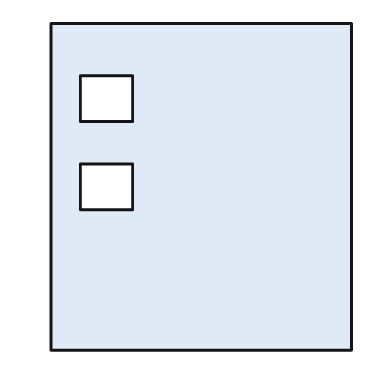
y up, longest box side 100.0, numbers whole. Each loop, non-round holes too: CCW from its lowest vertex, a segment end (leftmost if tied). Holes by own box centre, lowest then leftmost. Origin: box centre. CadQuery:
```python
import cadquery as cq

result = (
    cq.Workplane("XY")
    .moveTo(-46.0, -50.0)
    .lineTo(46.0, -50.0)
    .lineTo(46.0, 50.0)
    .lineTo(-46.0, 50.0)
    .close()
    .moveTo(-37.0, -7.0)
    .lineTo(-21.0, -7.0)
    .lineTo(-21.0, 7.0)
    .lineTo(-37.0, 7.0)
    .close()
    .moveTo(-37.0, 20.0)
    .lineTo(-21.0, 20.0)
    .lineTo(-21.0, 34.0)
    .lineTo(-37.0, 34.0)
    .close()
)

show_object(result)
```